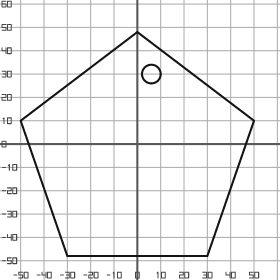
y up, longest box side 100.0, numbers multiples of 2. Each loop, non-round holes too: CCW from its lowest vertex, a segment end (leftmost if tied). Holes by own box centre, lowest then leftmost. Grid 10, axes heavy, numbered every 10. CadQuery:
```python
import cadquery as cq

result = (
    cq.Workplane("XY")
    .moveTo(-30.0, -48.0)
    .lineTo(30.0, -48.0)
    .lineTo(50.0, 10.0)
    .lineTo(0.0, 48.0)
    .lineTo(-50.0, 10.0)
    .close()
    .moveTo(6.0, 30.0)
    .circle(4.0)
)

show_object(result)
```